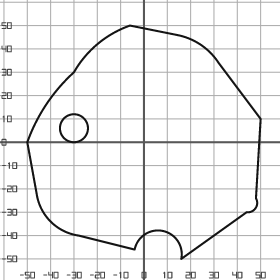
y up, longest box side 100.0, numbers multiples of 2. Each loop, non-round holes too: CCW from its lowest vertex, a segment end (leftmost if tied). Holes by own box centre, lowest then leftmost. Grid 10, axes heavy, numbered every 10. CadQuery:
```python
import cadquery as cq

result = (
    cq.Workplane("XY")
    .moveTo(16.0, -50.0)
    .lineTo(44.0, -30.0)
    .threePointArc((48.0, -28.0), (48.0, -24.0))
    .lineTo(50.0, 10.0)
    .lineTo(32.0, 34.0)
    .threePointArc((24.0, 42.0), (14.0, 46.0))
    .lineTo(-6.0, 50.0)
    .threePointArc((-20.0, 42.0), (-30.0, 30.0))
    .threePointArc((-42.0, 16.0), (-50.0, 0.0))
    .lineTo(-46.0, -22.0)
    .threePointArc((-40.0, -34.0), (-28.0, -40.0))
    .lineTo(-4.0, -46.0)
    .threePointArc((8.0, -38.0), (16.0, -50.0))
    .close()
    .moveTo(-30.0, 6.0)
    .circle(6.0)
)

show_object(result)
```